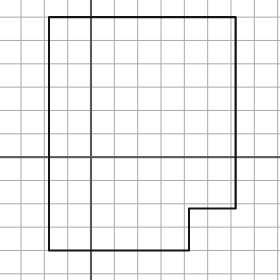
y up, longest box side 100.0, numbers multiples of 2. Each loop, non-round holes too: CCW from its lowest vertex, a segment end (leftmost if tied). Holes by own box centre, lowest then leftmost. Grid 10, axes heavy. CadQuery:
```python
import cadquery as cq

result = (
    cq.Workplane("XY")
    .moveTo(-18.0, -40.0)
    .lineTo(42.0, -40.0)
    .lineTo(42.0, -22.0)
    .lineTo(62.0, -22.0)
    .lineTo(62.0, 60.0)
    .lineTo(-18.0, 60.0)
    .close()
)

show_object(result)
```